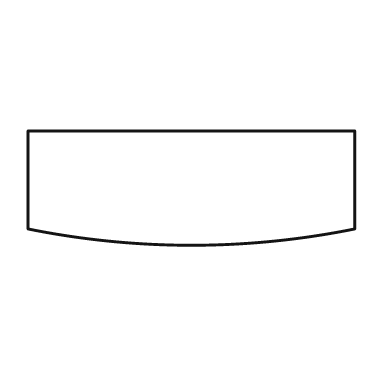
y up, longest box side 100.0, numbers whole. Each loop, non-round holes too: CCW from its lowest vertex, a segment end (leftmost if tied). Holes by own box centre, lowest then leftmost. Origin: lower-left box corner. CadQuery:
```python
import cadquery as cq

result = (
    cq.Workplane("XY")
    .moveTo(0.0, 5.0)
    .threePointArc((50.0, 0.0), (100.0, 5.0))
    .lineTo(100.0, 35.0)
    .lineTo(0.0, 35.0)
    .close()
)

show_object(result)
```